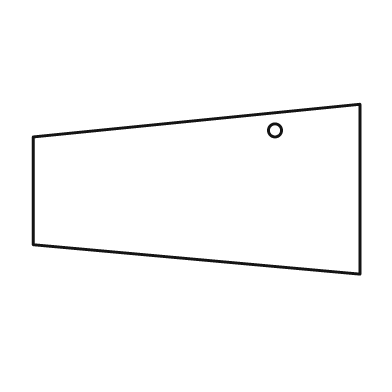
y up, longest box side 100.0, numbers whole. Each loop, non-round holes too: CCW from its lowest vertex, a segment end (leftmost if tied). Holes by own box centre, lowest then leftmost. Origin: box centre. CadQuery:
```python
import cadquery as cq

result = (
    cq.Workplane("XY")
    .moveTo(50.0, -26.0)
    .lineTo(50.0, 26.0)
    .lineTo(-50.0, 16.0)
    .lineTo(-50.0, -17.0)
    .close()
    .moveTo(24.0, 18.0)
    .circle(2.0)
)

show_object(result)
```